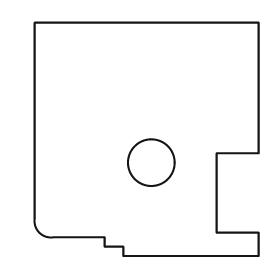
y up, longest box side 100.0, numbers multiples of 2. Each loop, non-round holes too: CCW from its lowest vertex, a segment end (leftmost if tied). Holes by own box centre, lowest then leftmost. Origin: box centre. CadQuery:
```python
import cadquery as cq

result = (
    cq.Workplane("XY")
    .moveTo(-10.0, -50.0)
    .lineTo(48.0, -50.0)
    .lineTo(48.0, -40.0)
    .lineTo(30.0, -40.0)
    .lineTo(30.0, -6.0)
    .lineTo(48.0, -6.0)
    .lineTo(48.0, 50.0)
    .lineTo(-48.0, 50.0)
    .lineTo(-48.0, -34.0)
    .threePointArc((-46.0, -40.0), (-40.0, -42.0))
    .lineTo(-18.0, -42.0)
    .lineTo(-18.0, -46.0)
    .lineTo(-10.0, -46.0)
    .close()
    .moveTo(2.0, -10.0)
    .circle(10.0)
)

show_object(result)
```